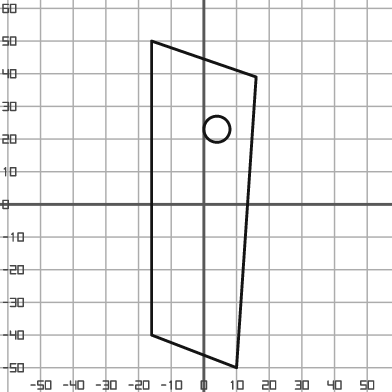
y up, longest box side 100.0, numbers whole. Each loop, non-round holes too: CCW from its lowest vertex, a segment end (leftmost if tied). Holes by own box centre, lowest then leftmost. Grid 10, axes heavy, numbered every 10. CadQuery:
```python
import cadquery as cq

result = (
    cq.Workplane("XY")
    .moveTo(10.0, -50.0)
    .lineTo(16.0, 39.0)
    .lineTo(-16.0, 50.0)
    .lineTo(-16.0, -40.0)
    .close()
    .moveTo(4.0, 23.0)
    .circle(4.0)
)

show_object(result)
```